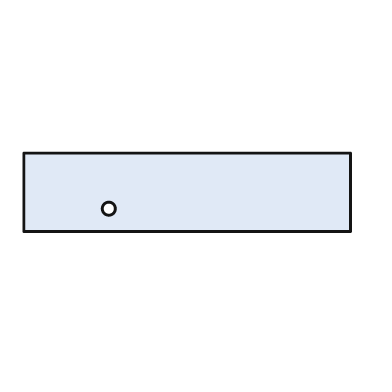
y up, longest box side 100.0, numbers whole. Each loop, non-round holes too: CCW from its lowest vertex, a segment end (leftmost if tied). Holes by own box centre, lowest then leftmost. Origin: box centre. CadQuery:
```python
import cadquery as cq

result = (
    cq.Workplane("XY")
    .moveTo(-50.0, -12.0)
    .lineTo(50.0, -12.0)
    .lineTo(50.0, 12.0)
    .lineTo(-50.0, 12.0)
    .close()
    .moveTo(-24.0, -5.0)
    .circle(2.0)
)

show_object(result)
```